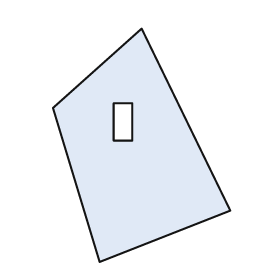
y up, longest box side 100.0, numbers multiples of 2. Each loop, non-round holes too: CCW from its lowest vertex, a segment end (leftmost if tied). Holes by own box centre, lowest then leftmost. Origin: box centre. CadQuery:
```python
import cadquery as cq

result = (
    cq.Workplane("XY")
    .moveTo(-18.0, -50.0)
    .lineTo(38.0, -28.0)
    .lineTo(0.0, 50.0)
    .lineTo(-38.0, 16.0)
    .close()
    .moveTo(-12.0, 2.0)
    .lineTo(-4.0, 2.0)
    .lineTo(-4.0, 18.0)
    .lineTo(-12.0, 18.0)
    .close()
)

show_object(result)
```